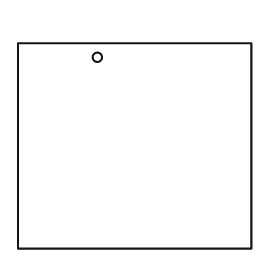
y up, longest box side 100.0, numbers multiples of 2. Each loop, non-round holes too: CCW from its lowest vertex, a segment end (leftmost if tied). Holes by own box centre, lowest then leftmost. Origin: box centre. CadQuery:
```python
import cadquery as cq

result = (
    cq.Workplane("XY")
    .moveTo(-50.0, -44.0)
    .lineTo(50.0, -44.0)
    .lineTo(50.0, 44.0)
    .lineTo(-50.0, 44.0)
    .close()
    .moveTo(-16.0, 38.0)
    .circle(2.0)
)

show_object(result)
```